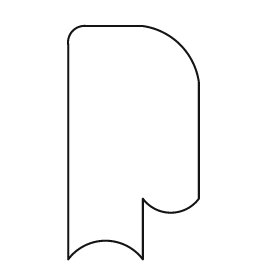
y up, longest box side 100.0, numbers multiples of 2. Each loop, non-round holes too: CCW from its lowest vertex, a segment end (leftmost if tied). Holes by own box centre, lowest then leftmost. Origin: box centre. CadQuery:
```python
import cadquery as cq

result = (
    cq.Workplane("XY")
    .moveTo(-28.0, -50.0)
    .threePointArc((-12.0, -42.0), (4.0, -50.0))
    .lineTo(4.0, -24.0)
    .threePointArc((16.0, -30.0), (28.0, -24.0))
    .lineTo(28.0, 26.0)
    .threePointArc((20.0, 42.0), (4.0, 50.0))
    .lineTo(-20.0, 50.0)
    .threePointArc((-26.0, 48.0), (-28.0, 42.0))
    .close()
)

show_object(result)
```